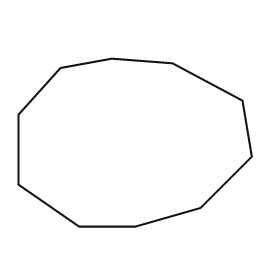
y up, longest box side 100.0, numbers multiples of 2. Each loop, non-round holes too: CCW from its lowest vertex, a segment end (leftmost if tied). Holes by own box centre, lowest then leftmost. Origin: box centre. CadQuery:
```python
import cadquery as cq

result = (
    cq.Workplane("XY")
    .moveTo(-24.0, -36.0)
    .lineTo(0.0, -36.0)
    .lineTo(28.0, -28.0)
    .lineTo(50.0, -6.0)
    .lineTo(46.0, 18.0)
    .lineTo(16.0, 34.0)
    .lineTo(-10.0, 36.0)
    .lineTo(-32.0, 32.0)
    .lineTo(-50.0, 12.0)
    .lineTo(-50.0, -18.0)
    .close()
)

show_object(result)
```